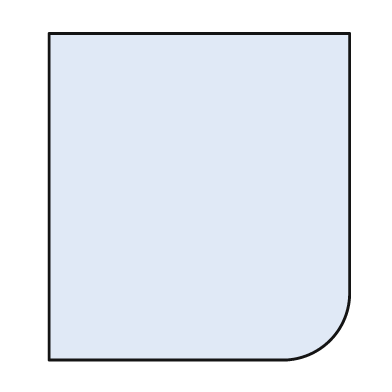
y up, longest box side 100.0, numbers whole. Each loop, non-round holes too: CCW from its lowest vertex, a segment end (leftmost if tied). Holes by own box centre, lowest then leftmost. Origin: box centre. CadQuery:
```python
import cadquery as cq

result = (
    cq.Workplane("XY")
    .moveTo(-46.0, -50.0)
    .lineTo(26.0, -50.0)
    .threePointArc((40.0, -44.0), (46.0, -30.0))
    .lineTo(46.0, 50.0)
    .lineTo(-46.0, 50.0)
    .close()
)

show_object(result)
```